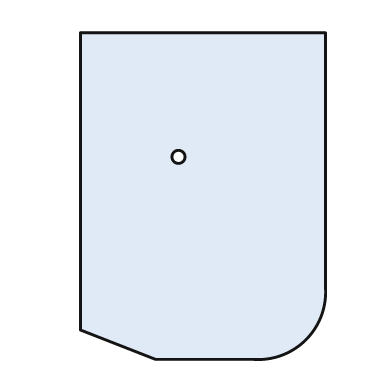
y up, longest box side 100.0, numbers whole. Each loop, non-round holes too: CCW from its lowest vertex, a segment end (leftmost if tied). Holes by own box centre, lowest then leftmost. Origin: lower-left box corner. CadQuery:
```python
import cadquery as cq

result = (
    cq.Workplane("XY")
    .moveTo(23.0, 0.0)
    .lineTo(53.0, 0.0)
    .threePointArc((69.0, 6.0), (75.0, 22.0))
    .lineTo(75.0, 100.0)
    .lineTo(0.0, 100.0)
    .lineTo(0.0, 9.0)
    .close()
    .moveTo(30.0, 62.0)
    .circle(2.0)
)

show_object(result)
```